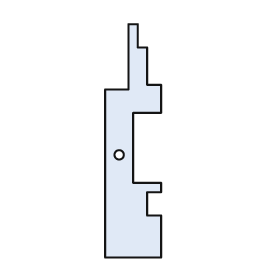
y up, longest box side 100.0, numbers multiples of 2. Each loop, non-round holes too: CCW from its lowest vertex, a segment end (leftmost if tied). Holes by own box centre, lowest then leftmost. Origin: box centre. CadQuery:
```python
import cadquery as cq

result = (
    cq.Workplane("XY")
    .moveTo(-12.0, -50.0)
    .lineTo(12.0, -50.0)
    .lineTo(12.0, -32.0)
    .lineTo(6.0, -32.0)
    .lineTo(6.0, -22.0)
    .lineTo(12.0, -22.0)
    .lineTo(12.0, -18.0)
    .lineTo(0.0, -18.0)
    .lineTo(0.0, 12.0)
    .lineTo(12.0, 12.0)
    .lineTo(12.0, 24.0)
    .lineTo(6.0, 24.0)
    .lineTo(6.0, 40.0)
    .lineTo(2.0, 40.0)
    .lineTo(2.0, 50.0)
    .lineTo(-2.0, 50.0)
    .lineTo(-2.0, 22.0)
    .lineTo(-12.0, 22.0)
    .close()
    .moveTo(-6.0, -6.0)
    .circle(2.0)
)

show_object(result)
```